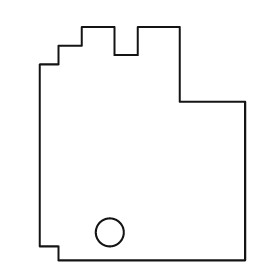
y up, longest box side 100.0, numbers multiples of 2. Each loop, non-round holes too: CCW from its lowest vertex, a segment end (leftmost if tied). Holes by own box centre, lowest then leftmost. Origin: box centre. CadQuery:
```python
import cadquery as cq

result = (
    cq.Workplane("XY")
    .moveTo(-36.0, -50.0)
    .lineTo(44.0, -50.0)
    .lineTo(44.0, 18.0)
    .lineTo(16.0, 18.0)
    .lineTo(16.0, 50.0)
    .lineTo(-2.0, 50.0)
    .lineTo(-2.0, 38.0)
    .lineTo(-12.0, 38.0)
    .lineTo(-12.0, 50.0)
    .lineTo(-26.0, 50.0)
    .lineTo(-26.0, 42.0)
    .lineTo(-36.0, 42.0)
    .lineTo(-36.0, 34.0)
    .lineTo(-44.0, 34.0)
    .lineTo(-44.0, -44.0)
    .lineTo(-36.0, -44.0)
    .close()
    .moveTo(-14.0, -38.0)
    .circle(6.0)
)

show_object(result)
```